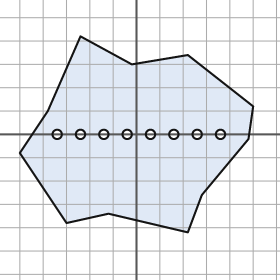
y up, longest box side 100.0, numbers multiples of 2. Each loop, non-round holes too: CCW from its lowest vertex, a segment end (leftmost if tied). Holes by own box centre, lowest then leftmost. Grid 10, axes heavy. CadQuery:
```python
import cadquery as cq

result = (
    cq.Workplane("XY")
    .moveTo(22.0, -42.0)
    .lineTo(28.0, -26.0)
    .lineTo(48.0, -2.0)
    .lineTo(50.0, 12.0)
    .lineTo(22.0, 34.0)
    .lineTo(-2.0, 30.0)
    .lineTo(-24.0, 42.0)
    .lineTo(-38.0, 10.0)
    .lineTo(-50.0, -8.0)
    .lineTo(-30.0, -38.0)
    .lineTo(-12.0, -34.0)
    .close()
    .moveTo(-34.0, 0.0)
    .circle(2.0)
    .moveTo(-24.0, 0.0)
    .circle(2.0)
    .moveTo(-14.0, 0.0)
    .circle(2.0)
    .moveTo(-4.0, 0.0)
    .circle(2.0)
    .moveTo(6.0, 0.0)
    .circle(2.0)
    .moveTo(16.0, 0.0)
    .circle(2.0)
    .moveTo(26.0, 0.0)
    .circle(2.0)
    .moveTo(36.0, 0.0)
    .circle(2.0)
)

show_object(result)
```